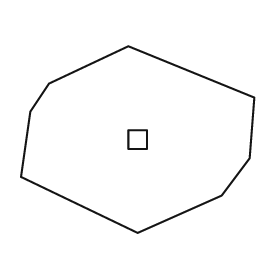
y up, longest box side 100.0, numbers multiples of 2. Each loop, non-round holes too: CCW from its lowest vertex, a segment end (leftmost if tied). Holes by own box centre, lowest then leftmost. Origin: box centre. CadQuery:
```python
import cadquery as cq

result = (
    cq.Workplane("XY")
    .moveTo(0.0, -40.0)
    .lineTo(36.0, -24.0)
    .lineTo(48.0, -8.0)
    .lineTo(50.0, 18.0)
    .lineTo(-4.0, 40.0)
    .lineTo(-38.0, 24.0)
    .lineTo(-46.0, 12.0)
    .lineTo(-50.0, -16.0)
    .close()
    .moveTo(-4.0, -4.0)
    .lineTo(4.0, -4.0)
    .lineTo(4.0, 4.0)
    .lineTo(-4.0, 4.0)
    .close()
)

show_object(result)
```